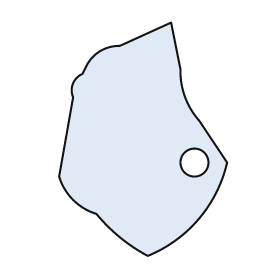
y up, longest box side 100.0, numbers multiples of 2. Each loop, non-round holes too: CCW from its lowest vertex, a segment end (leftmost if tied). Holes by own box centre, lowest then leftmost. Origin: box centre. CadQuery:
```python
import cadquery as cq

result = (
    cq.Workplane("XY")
    .moveTo(2.0, -50.0)
    .threePointArc((24.0, -34.0), (36.0, -10.0))
    .lineTo(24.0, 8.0)
    .threePointArc((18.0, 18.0), (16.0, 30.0))
    .lineTo(12.0, 50.0)
    .lineTo(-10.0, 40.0)
    .threePointArc((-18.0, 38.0), (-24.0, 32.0))
    .lineTo(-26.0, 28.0)
    .threePointArc((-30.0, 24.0), (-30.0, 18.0))
    .lineTo(-36.0, -16.0)
    .threePointArc((-30.0, -26.0), (-20.0, -32.0))
    .threePointArc((-10.0, -42.0), (2.0, -50.0))
    .close()
    .moveTo(22.0, -10.0)
    .circle(6.0)
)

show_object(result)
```